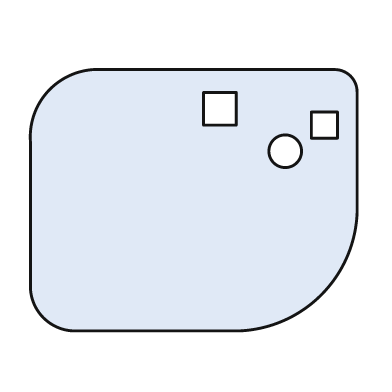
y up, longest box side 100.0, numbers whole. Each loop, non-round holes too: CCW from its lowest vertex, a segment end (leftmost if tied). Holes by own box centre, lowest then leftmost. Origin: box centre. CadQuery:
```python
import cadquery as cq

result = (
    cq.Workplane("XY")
    .moveTo(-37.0, -40.0)
    .lineTo(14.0, -40.0)
    .threePointArc((39.0, -29.0), (50.0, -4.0))
    .lineTo(50.0, 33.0)
    .threePointArc((48.0, 38.0), (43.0, 40.0))
    .lineTo(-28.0, 40.0)
    .threePointArc((-44.0, 34.0), (-50.0, 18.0))
    .lineTo(-50.0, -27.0)
    .threePointArc((-46.0, -36.0), (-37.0, -40.0))
    .close()
    .moveTo(28.0, 15.0)
    .circle(5.0)
    .moveTo(36.0, 19.0)
    .lineTo(44.0, 19.0)
    .lineTo(44.0, 27.0)
    .lineTo(36.0, 27.0)
    .close()
    .moveTo(3.0, 23.0)
    .lineTo(13.0, 23.0)
    .lineTo(13.0, 33.0)
    .lineTo(3.0, 33.0)
    .close()
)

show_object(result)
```